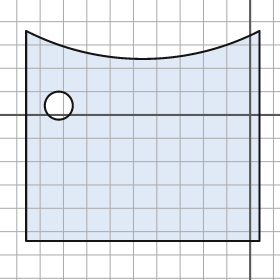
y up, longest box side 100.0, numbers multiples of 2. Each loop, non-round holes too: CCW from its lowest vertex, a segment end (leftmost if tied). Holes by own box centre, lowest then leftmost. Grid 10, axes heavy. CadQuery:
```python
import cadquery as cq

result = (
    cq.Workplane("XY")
    .moveTo(-96.0, -54.0)
    .lineTo(4.0, -54.0)
    .lineTo(4.0, 36.0)
    .threePointArc((-46.0, 24.0), (-96.0, 36.0))
    .close()
    .moveTo(-82.0, 4.0)
    .circle(6.0)
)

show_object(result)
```